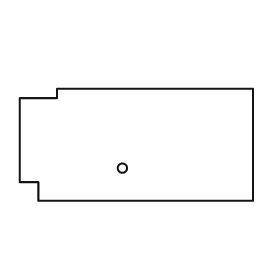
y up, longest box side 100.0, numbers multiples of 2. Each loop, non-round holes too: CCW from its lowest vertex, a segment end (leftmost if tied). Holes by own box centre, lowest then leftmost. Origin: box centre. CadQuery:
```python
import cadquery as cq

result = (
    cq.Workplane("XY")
    .moveTo(-42.0, -24.0)
    .lineTo(50.0, -24.0)
    .lineTo(50.0, 24.0)
    .lineTo(-34.0, 24.0)
    .lineTo(-34.0, 20.0)
    .lineTo(-50.0, 20.0)
    .lineTo(-50.0, -16.0)
    .lineTo(-42.0, -16.0)
    .close()
    .moveTo(-6.0, -10.0)
    .circle(2.0)
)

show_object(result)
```